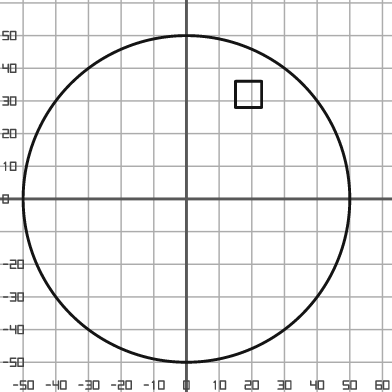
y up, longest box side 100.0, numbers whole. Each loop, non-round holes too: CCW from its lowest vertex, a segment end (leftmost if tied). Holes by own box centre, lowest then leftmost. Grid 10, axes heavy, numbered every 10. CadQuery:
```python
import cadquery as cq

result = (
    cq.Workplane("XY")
    .moveTo(0.0, 0.0)
    .circle(50.0)
    .moveTo(15.0, 28.0)
    .lineTo(23.0, 28.0)
    .lineTo(23.0, 36.0)
    .lineTo(15.0, 36.0)
    .close()
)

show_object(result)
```